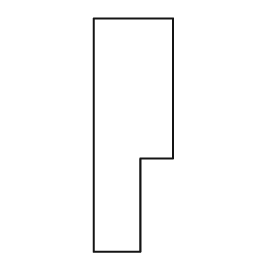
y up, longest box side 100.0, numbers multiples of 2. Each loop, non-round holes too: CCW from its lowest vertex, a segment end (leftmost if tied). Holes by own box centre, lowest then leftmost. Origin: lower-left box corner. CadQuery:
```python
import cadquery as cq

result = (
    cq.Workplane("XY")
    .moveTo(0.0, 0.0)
    .lineTo(20.0, 0.0)
    .lineTo(20.0, 40.0)
    .lineTo(34.0, 40.0)
    .lineTo(34.0, 100.0)
    .lineTo(0.0, 100.0)
    .close()
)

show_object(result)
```